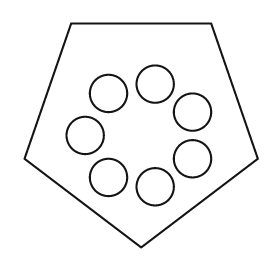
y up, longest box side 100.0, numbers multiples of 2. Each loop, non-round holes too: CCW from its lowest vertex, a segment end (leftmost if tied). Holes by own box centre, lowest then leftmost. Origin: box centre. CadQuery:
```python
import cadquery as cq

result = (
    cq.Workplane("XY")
    .moveTo(0.0, -48.0)
    .lineTo(50.0, -10.0)
    .lineTo(30.0, 48.0)
    .lineTo(-30.0, 48.0)
    .lineTo(-50.0, -10.0)
    .close()
    .moveTo(6.0, -22.0)
    .circle(8.0)
    .moveTo(-14.0, -18.0)
    .circle(8.0)
    .moveTo(22.0, -10.0)
    .circle(8.0)
    .moveTo(-24.0, 0.0)
    .circle(8.0)
    .moveTo(22.0, 10.0)
    .circle(8.0)
    .moveTo(-14.0, 18.0)
    .circle(8.0)
    .moveTo(6.0, 22.0)
    .circle(8.0)
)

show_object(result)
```